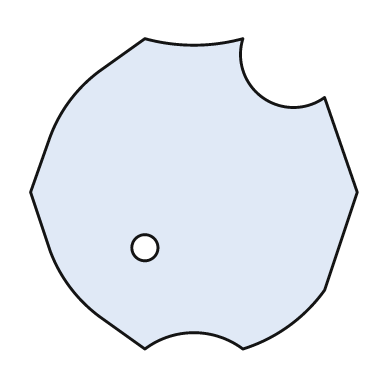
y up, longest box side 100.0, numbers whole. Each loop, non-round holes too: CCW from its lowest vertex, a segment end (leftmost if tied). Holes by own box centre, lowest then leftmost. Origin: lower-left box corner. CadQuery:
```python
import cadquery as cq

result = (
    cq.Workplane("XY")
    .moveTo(35.0, 0.0)
    .threePointArc((50.0, 5.0), (65.0, 0.0))
    .threePointArc((79.0, 7.0), (90.0, 18.0))
    .lineTo(100.0, 48.0)
    .lineTo(90.0, 77.0)
    .threePointArc((71.0, 77.0), (65.0, 95.0))
    .threePointArc((50.0, 93.0), (35.0, 95.0))
    .lineTo(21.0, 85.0)
    .threePointArc((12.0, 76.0), (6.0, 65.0))
    .lineTo(0.0, 48.0)
    .lineTo(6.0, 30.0)
    .threePointArc((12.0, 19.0), (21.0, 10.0))
    .close()
    .moveTo(35.0, 31.0)
    .circle(4.0)
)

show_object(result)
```